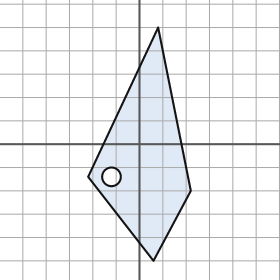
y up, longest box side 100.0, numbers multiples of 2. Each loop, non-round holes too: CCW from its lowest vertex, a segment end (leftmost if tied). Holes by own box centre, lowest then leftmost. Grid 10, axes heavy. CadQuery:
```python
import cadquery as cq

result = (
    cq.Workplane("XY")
    .moveTo(6.0, -50.0)
    .lineTo(22.0, -20.0)
    .lineTo(8.0, 50.0)
    .lineTo(-22.0, -14.0)
    .close()
    .moveTo(-12.0, -14.0)
    .circle(4.0)
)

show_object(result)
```